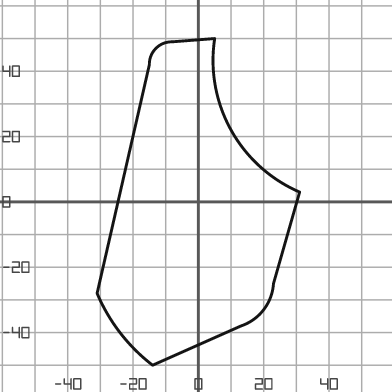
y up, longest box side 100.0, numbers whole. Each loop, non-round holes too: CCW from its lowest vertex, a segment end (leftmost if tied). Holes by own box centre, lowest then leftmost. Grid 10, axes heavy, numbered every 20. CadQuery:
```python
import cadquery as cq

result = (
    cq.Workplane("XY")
    .moveTo(-14.0, -50.0)
    .lineTo(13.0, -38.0)
    .threePointArc((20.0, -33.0), (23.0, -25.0))
    .lineTo(31.0, 3.0)
    .threePointArc((10.0, 22.0), (5.0, 50.0))
    .lineTo(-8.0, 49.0)
    .threePointArc((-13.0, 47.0), (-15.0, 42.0))
    .lineTo(-31.0, -28.0)
    .threePointArc((-24.0, -40.0), (-14.0, -50.0))
    .close()
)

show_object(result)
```